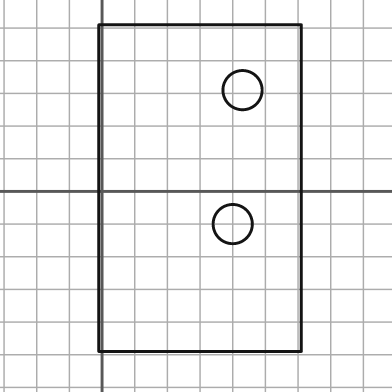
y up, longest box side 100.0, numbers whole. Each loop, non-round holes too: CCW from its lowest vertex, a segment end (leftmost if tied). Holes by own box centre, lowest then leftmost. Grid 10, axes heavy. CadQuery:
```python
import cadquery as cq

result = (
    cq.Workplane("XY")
    .moveTo(-1.0, -49.0)
    .lineTo(61.0, -49.0)
    .lineTo(61.0, 51.0)
    .lineTo(-1.0, 51.0)
    .close()
    .moveTo(40.0, -10.0)
    .circle(6.0)
    .moveTo(43.0, 31.0)
    .circle(6.0)
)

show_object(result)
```